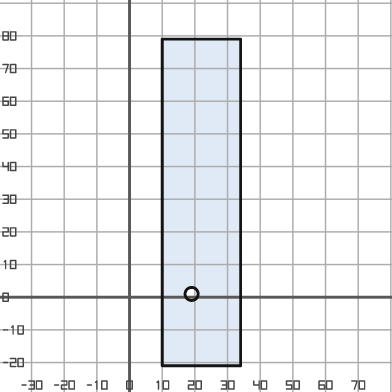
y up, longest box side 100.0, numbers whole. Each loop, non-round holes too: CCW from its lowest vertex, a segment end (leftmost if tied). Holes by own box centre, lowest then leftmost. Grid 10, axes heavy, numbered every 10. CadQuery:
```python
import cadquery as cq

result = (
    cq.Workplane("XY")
    .moveTo(10.0, -21.0)
    .lineTo(34.0, -21.0)
    .lineTo(34.0, 79.0)
    .lineTo(10.0, 79.0)
    .close()
    .moveTo(19.0, 1.0)
    .circle(2.0)
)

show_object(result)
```